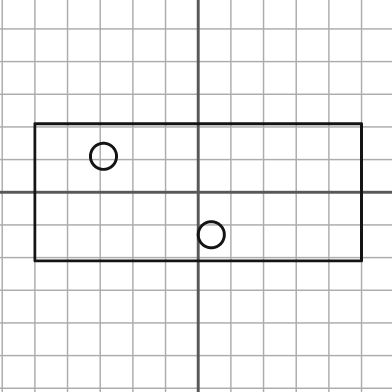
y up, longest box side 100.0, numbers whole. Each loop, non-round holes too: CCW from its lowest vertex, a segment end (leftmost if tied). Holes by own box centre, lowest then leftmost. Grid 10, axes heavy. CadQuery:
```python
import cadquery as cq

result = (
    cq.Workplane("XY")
    .moveTo(-50.0, -21.0)
    .lineTo(50.0, -21.0)
    .lineTo(50.0, 21.0)
    .lineTo(-50.0, 21.0)
    .close()
    .moveTo(4.0, -13.0)
    .circle(4.0)
    .moveTo(-29.0, 11.0)
    .circle(4.0)
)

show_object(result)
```